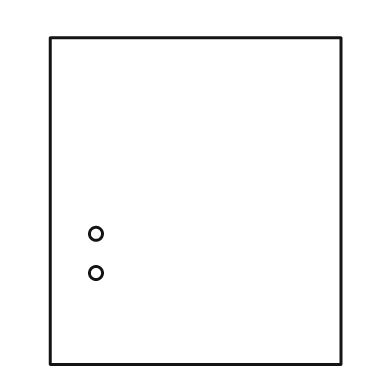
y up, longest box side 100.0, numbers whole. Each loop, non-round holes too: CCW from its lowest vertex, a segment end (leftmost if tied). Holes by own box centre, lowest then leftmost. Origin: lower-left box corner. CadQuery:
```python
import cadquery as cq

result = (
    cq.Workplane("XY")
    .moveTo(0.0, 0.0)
    .lineTo(89.0, 0.0)
    .lineTo(89.0, 100.0)
    .lineTo(0.0, 100.0)
    .close()
    .moveTo(14.0, 28.0)
    .circle(2.0)
    .moveTo(14.0, 40.0)
    .circle(2.0)
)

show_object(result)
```